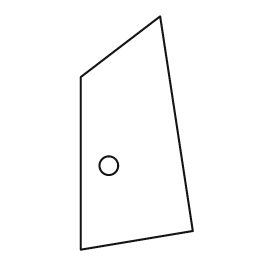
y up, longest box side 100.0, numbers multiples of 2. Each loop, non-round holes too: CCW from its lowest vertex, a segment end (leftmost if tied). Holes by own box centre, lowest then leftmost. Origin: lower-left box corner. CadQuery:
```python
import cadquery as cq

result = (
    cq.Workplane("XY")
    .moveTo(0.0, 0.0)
    .lineTo(48.0, 8.0)
    .lineTo(34.0, 100.0)
    .lineTo(0.0, 74.0)
    .close()
    .moveTo(12.0, 36.0)
    .circle(4.0)
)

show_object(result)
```